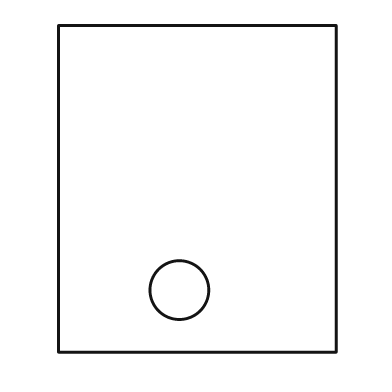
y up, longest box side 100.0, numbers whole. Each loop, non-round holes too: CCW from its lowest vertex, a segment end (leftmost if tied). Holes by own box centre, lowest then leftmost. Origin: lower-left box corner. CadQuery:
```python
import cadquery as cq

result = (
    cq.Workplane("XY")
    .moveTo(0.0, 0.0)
    .lineTo(85.0, 0.0)
    .lineTo(85.0, 100.0)
    .lineTo(0.0, 100.0)
    .close()
    .moveTo(37.0, 19.0)
    .circle(9.0)
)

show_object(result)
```